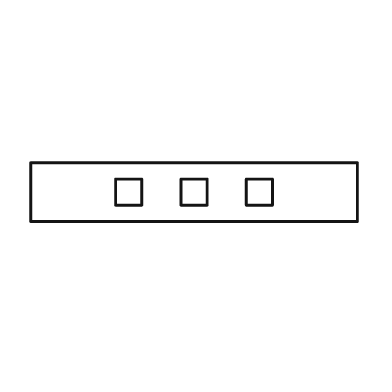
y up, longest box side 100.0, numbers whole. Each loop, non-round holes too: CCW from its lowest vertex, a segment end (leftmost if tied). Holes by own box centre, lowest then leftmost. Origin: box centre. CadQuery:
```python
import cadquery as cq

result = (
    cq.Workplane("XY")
    .moveTo(-50.0, -9.0)
    .lineTo(50.0, -9.0)
    .lineTo(50.0, 9.0)
    .lineTo(-50.0, 9.0)
    .close()
    .moveTo(-24.0, -4.0)
    .lineTo(-16.0, -4.0)
    .lineTo(-16.0, 4.0)
    .lineTo(-24.0, 4.0)
    .close()
    .moveTo(-4.0, -4.0)
    .lineTo(4.0, -4.0)
    .lineTo(4.0, 4.0)
    .lineTo(-4.0, 4.0)
    .close()
    .moveTo(16.0, -4.0)
    .lineTo(24.0, -4.0)
    .lineTo(24.0, 4.0)
    .lineTo(16.0, 4.0)
    .close()
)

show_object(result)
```